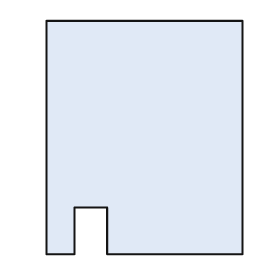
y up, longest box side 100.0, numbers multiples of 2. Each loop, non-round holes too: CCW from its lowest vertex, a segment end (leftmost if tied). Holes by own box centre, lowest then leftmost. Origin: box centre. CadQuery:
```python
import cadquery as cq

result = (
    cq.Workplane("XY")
    .moveTo(-42.0, -50.0)
    .lineTo(-30.0, -50.0)
    .lineTo(-30.0, -30.0)
    .lineTo(-16.0, -30.0)
    .lineTo(-16.0, -50.0)
    .lineTo(42.0, -50.0)
    .lineTo(42.0, 50.0)
    .lineTo(-42.0, 50.0)
    .close()
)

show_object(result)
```